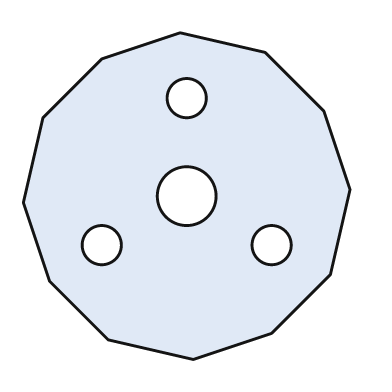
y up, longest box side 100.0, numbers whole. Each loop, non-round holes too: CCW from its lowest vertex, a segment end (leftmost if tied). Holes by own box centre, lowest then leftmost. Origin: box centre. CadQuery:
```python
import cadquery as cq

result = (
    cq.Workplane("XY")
    .moveTo(2.0, -50.0)
    .lineTo(26.0, -42.0)
    .lineTo(44.0, -24.0)
    .lineTo(50.0, 2.0)
    .lineTo(42.0, 26.0)
    .lineTo(24.0, 44.0)
    .lineTo(-2.0, 50.0)
    .lineTo(-26.0, 42.0)
    .lineTo(-44.0, 24.0)
    .lineTo(-50.0, -2.0)
    .lineTo(-42.0, -26.0)
    .lineTo(-24.0, -44.0)
    .close()
    .moveTo(-26.0, -15.0)
    .circle(6.0)
    .moveTo(26.0, -15.0)
    .circle(6.0)
    .moveTo(0.0, 0.0)
    .circle(9.0)
    .moveTo(0.0, 30.0)
    .circle(6.0)
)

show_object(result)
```